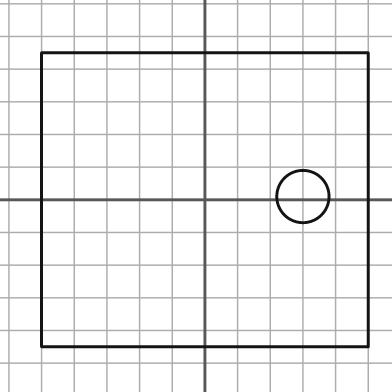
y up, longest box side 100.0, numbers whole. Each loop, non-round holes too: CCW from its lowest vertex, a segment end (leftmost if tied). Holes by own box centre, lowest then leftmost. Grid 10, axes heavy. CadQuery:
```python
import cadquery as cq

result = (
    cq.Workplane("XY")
    .moveTo(-50.0, -45.0)
    .lineTo(50.0, -45.0)
    .lineTo(50.0, 45.0)
    .lineTo(-50.0, 45.0)
    .close()
    .moveTo(30.0, 1.0)
    .circle(8.0)
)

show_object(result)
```